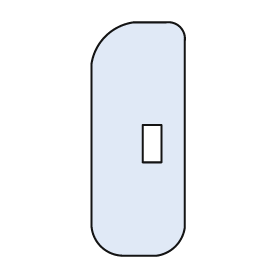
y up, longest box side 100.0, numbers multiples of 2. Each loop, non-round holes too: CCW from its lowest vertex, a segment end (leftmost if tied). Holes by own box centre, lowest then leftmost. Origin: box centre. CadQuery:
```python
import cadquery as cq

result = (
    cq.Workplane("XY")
    .moveTo(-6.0, -50.0)
    .lineTo(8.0, -50.0)
    .threePointArc((16.0, -46.0), (20.0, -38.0))
    .lineTo(20.0, 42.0)
    .threePointArc((18.0, 48.0), (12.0, 50.0))
    .lineTo(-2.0, 50.0)
    .threePointArc((-14.0, 44.0), (-20.0, 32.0))
    .lineTo(-20.0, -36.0)
    .threePointArc((-16.0, -46.0), (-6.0, -50.0))
    .close()
    .moveTo(2.0, -10.0)
    .lineTo(10.0, -10.0)
    .lineTo(10.0, 6.0)
    .lineTo(2.0, 6.0)
    .close()
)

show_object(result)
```